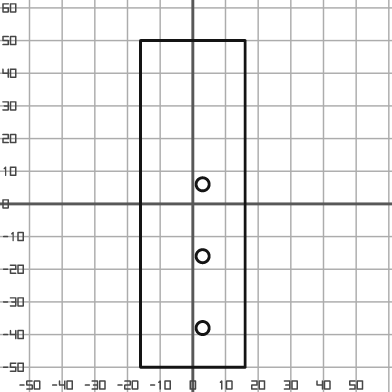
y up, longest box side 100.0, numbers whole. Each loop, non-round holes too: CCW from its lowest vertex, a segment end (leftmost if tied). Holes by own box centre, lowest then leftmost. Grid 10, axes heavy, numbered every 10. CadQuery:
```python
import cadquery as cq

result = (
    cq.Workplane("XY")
    .moveTo(-16.0, -50.0)
    .lineTo(16.0, -50.0)
    .lineTo(16.0, 50.0)
    .lineTo(-16.0, 50.0)
    .close()
    .moveTo(3.0, -38.0)
    .circle(2.0)
    .moveTo(3.0, -16.0)
    .circle(2.0)
    .moveTo(3.0, 6.0)
    .circle(2.0)
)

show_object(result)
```